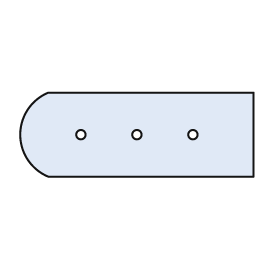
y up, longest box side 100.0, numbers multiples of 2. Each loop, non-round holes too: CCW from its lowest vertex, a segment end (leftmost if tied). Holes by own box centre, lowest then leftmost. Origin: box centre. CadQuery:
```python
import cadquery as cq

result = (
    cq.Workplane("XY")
    .moveTo(-38.0, -18.0)
    .lineTo(50.0, -18.0)
    .lineTo(50.0, 18.0)
    .lineTo(-38.0, 18.0)
    .threePointArc((-50.0, 0.0), (-38.0, -18.0))
    .close()
    .moveTo(-24.0, 0.0)
    .circle(2.0)
    .moveTo(0.0, 0.0)
    .circle(2.0)
    .moveTo(24.0, 0.0)
    .circle(2.0)
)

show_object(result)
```